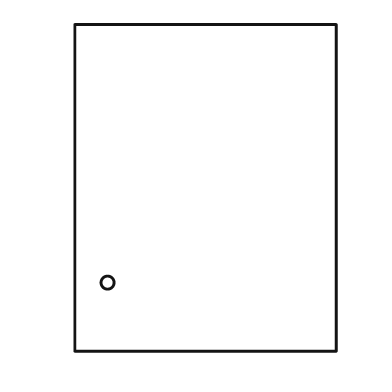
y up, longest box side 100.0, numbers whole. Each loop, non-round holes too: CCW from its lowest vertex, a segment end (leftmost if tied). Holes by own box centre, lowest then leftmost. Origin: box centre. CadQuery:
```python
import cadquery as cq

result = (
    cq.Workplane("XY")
    .moveTo(-40.0, -50.0)
    .lineTo(40.0, -50.0)
    .lineTo(40.0, 50.0)
    .lineTo(-40.0, 50.0)
    .close()
    .moveTo(-30.0, -29.0)
    .circle(2.0)
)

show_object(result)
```